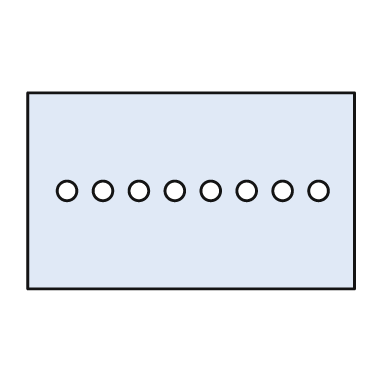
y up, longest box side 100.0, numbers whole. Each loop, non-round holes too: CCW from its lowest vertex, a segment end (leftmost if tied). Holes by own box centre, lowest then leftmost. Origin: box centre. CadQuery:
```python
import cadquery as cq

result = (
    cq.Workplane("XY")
    .moveTo(-50.0, -30.0)
    .lineTo(50.0, -30.0)
    .lineTo(50.0, 30.0)
    .lineTo(-50.0, 30.0)
    .close()
    .moveTo(-38.0, 0.0)
    .circle(3.0)
    .moveTo(-27.0, 0.0)
    .circle(3.0)
    .moveTo(-16.0, 0.0)
    .circle(3.0)
    .moveTo(-5.0, 0.0)
    .circle(3.0)
    .moveTo(6.0, 0.0)
    .circle(3.0)
    .moveTo(17.0, 0.0)
    .circle(3.0)
    .moveTo(28.0, 0.0)
    .circle(3.0)
    .moveTo(39.0, 0.0)
    .circle(3.0)
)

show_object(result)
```